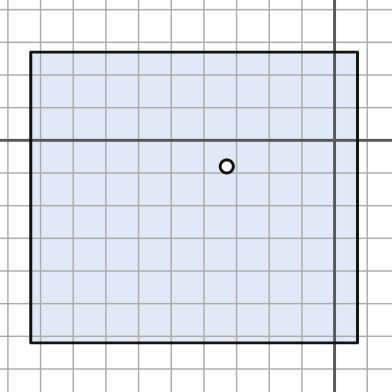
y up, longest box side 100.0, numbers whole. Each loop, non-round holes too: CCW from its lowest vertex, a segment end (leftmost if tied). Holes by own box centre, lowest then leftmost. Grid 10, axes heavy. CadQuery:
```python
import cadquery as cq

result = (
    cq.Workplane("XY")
    .moveTo(-93.0, -62.0)
    .lineTo(7.0, -62.0)
    .lineTo(7.0, 27.0)
    .lineTo(-93.0, 27.0)
    .close()
    .moveTo(-33.0, -8.0)
    .circle(2.0)
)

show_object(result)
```